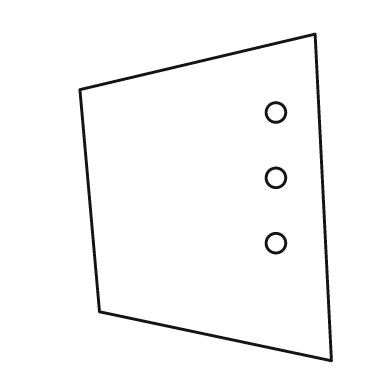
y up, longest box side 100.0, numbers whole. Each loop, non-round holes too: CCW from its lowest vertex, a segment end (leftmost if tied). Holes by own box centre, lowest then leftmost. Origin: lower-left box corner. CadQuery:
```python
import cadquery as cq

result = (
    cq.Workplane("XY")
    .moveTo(77.0, 0.0)
    .lineTo(72.0, 100.0)
    .lineTo(0.0, 83.0)
    .lineTo(6.0, 15.0)
    .close()
    .moveTo(60.0, 36.0)
    .circle(3.0)
    .moveTo(60.0, 56.0)
    .circle(3.0)
    .moveTo(60.0, 76.0)
    .circle(3.0)
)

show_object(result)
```